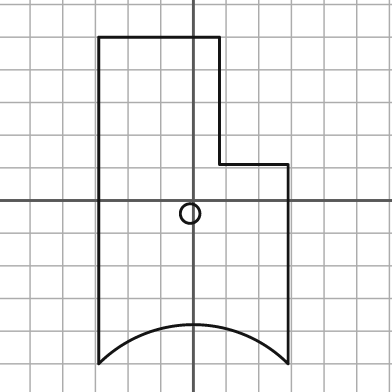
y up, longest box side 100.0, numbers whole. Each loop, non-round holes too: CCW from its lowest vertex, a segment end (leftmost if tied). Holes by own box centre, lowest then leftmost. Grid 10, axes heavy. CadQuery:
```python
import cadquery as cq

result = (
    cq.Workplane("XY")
    .moveTo(-29.0, -50.0)
    .threePointArc((0.0, -38.0), (29.0, -50.0))
    .lineTo(29.0, 11.0)
    .lineTo(8.0, 11.0)
    .lineTo(8.0, 50.0)
    .lineTo(-29.0, 50.0)
    .close()
    .moveTo(-1.0, -4.0)
    .circle(3.0)
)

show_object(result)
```